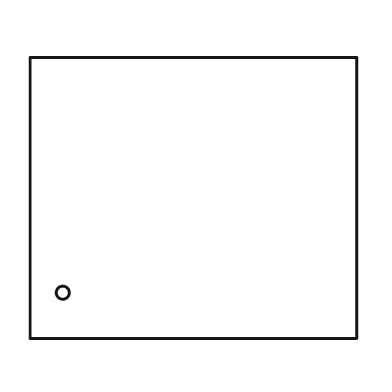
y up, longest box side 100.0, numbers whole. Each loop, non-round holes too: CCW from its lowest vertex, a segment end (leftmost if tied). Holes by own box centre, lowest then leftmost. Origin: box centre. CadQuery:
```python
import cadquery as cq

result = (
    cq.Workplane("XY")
    .moveTo(-50.0, -43.0)
    .lineTo(50.0, -43.0)
    .lineTo(50.0, 43.0)
    .lineTo(-50.0, 43.0)
    .close()
    .moveTo(-40.0, -29.0)
    .circle(2.0)
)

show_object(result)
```